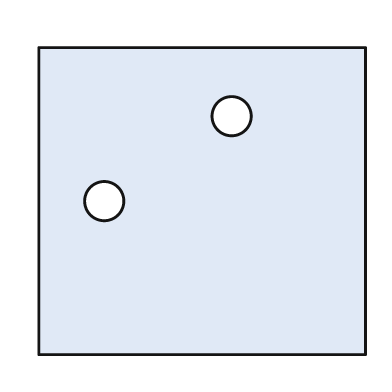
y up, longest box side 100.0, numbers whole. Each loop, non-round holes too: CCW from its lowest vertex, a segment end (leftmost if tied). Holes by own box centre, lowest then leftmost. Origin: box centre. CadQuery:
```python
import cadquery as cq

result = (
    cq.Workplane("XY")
    .moveTo(-50.0, -47.0)
    .lineTo(50.0, -47.0)
    .lineTo(50.0, 47.0)
    .lineTo(-50.0, 47.0)
    .close()
    .moveTo(-30.0, 0.0)
    .circle(6.0)
    .moveTo(9.0, 26.0)
    .circle(6.0)
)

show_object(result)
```